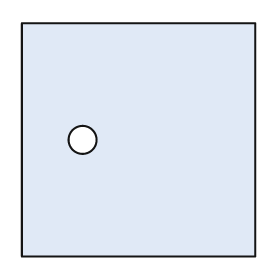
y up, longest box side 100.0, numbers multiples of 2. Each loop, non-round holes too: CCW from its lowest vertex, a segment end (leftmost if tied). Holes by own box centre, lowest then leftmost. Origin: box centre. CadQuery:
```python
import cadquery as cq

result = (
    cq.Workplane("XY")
    .moveTo(-50.0, -50.0)
    .lineTo(50.0, -50.0)
    .lineTo(50.0, 50.0)
    .lineTo(-50.0, 50.0)
    .close()
    .moveTo(-24.0, 0.0)
    .circle(6.0)
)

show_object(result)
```